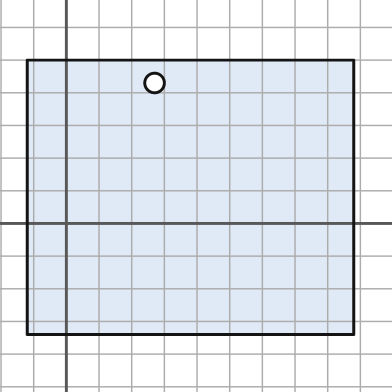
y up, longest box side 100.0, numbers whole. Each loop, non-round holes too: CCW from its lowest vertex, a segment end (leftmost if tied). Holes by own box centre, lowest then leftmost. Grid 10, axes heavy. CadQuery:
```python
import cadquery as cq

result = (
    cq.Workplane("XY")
    .moveTo(-12.0, -34.0)
    .lineTo(88.0, -34.0)
    .lineTo(88.0, 50.0)
    .lineTo(-12.0, 50.0)
    .close()
    .moveTo(27.0, 43.0)
    .circle(3.0)
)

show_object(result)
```